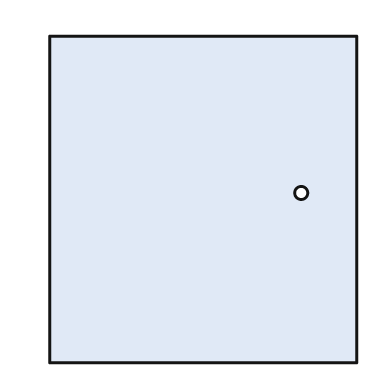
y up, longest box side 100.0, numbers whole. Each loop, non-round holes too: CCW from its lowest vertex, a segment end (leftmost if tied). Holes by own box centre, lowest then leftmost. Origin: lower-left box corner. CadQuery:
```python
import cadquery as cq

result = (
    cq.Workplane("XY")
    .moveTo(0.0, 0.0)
    .lineTo(94.0, 0.0)
    .lineTo(94.0, 100.0)
    .lineTo(0.0, 100.0)
    .close()
    .moveTo(77.0, 52.0)
    .circle(2.0)
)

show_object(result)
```